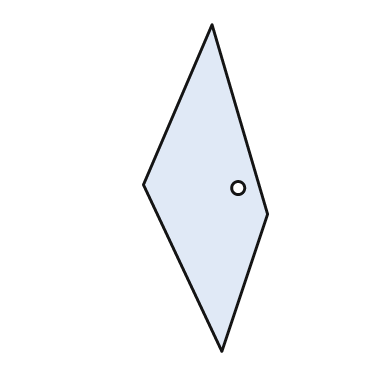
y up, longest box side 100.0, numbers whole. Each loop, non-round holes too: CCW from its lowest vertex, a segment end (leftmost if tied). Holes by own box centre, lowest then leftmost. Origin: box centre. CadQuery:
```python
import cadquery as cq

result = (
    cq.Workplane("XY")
    .moveTo(5.0, -50.0)
    .lineTo(19.0, -8.0)
    .lineTo(2.0, 50.0)
    .lineTo(-19.0, 1.0)
    .close()
    .moveTo(10.0, 0.0)
    .circle(2.0)
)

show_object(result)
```